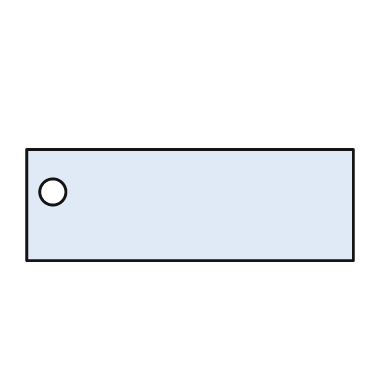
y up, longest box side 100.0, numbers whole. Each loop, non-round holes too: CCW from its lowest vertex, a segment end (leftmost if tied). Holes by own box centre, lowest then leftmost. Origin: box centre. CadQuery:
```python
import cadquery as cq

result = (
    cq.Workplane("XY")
    .moveTo(-50.0, -17.0)
    .lineTo(50.0, -17.0)
    .lineTo(50.0, 17.0)
    .lineTo(-50.0, 17.0)
    .close()
    .moveTo(-42.0, 4.0)
    .circle(4.0)
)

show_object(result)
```